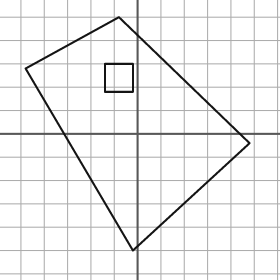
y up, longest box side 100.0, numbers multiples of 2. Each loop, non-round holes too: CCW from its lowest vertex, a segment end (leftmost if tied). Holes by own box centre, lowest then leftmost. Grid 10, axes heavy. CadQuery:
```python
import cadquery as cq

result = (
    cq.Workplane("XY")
    .moveTo(-2.0, -50.0)
    .lineTo(48.0, -4.0)
    .lineTo(-8.0, 50.0)
    .lineTo(-48.0, 28.0)
    .close()
    .moveTo(-14.0, 18.0)
    .lineTo(-2.0, 18.0)
    .lineTo(-2.0, 30.0)
    .lineTo(-14.0, 30.0)
    .close()
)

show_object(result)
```